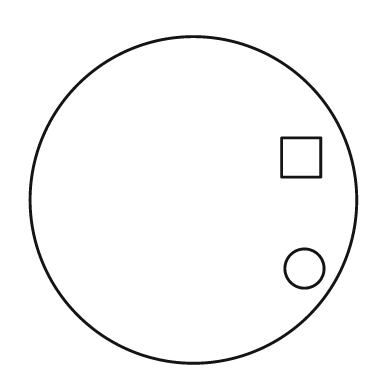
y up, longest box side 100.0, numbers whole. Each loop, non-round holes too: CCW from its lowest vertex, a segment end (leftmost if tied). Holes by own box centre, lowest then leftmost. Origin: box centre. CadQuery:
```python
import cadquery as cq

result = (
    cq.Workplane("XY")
    .moveTo(0.0, 0.0)
    .circle(50.0)
    .moveTo(34.0, -21.0)
    .circle(6.0)
    .moveTo(27.0, 7.0)
    .lineTo(39.0, 7.0)
    .lineTo(39.0, 19.0)
    .lineTo(27.0, 19.0)
    .close()
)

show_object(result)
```